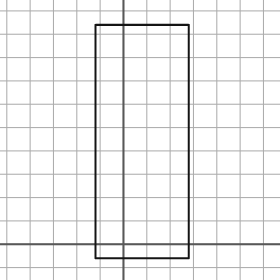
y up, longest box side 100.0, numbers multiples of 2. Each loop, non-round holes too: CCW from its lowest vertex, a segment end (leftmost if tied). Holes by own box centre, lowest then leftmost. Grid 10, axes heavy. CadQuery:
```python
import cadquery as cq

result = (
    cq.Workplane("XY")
    .moveTo(-12.0, -6.0)
    .lineTo(28.0, -6.0)
    .lineTo(28.0, 94.0)
    .lineTo(-12.0, 94.0)
    .close()
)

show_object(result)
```